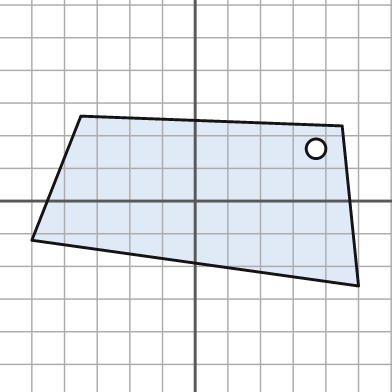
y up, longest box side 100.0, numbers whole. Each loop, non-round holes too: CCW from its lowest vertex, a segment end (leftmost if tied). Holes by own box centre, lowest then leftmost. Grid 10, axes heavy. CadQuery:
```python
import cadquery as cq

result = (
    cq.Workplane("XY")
    .moveTo(50.0, -26.0)
    .lineTo(45.0, 23.0)
    .lineTo(-35.0, 26.0)
    .lineTo(-50.0, -12.0)
    .close()
    .moveTo(37.0, 16.0)
    .circle(3.0)
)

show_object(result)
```